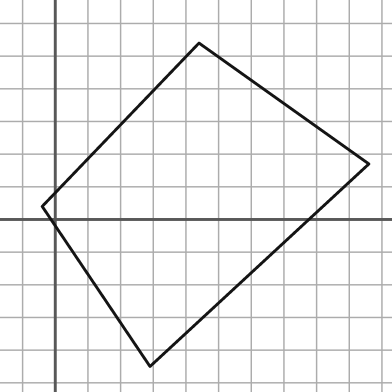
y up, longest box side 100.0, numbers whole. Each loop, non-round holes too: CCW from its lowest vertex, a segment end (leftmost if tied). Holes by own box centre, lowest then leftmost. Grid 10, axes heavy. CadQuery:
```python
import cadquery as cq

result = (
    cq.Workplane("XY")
    .moveTo(29.0, -45.0)
    .lineTo(96.0, 17.0)
    .lineTo(44.0, 54.0)
    .lineTo(-4.0, 4.0)
    .close()
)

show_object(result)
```